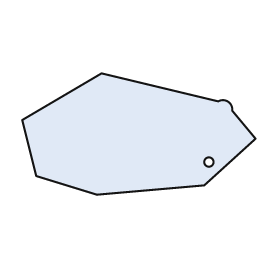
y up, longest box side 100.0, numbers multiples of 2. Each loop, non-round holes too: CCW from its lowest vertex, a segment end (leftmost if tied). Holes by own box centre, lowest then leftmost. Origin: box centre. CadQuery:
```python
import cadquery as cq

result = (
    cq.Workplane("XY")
    .moveTo(-18.0, -26.0)
    .lineTo(28.0, -22.0)
    .lineTo(50.0, -2.0)
    .lineTo(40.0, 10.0)
    .threePointArc((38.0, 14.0), (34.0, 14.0))
    .lineTo(-16.0, 26.0)
    .lineTo(-50.0, 6.0)
    .lineTo(-44.0, -18.0)
    .close()
    .moveTo(30.0, -12.0)
    .circle(2.0)
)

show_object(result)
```